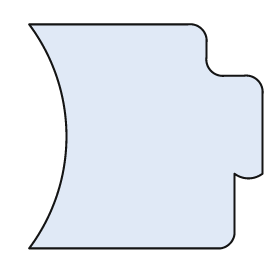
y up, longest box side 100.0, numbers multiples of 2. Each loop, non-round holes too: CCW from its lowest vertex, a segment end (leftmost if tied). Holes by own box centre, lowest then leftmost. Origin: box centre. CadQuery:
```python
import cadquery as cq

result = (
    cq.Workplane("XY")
    .moveTo(-50.0, -48.0)
    .lineTo(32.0, -48.0)
    .threePointArc((36.0, -46.0), (38.0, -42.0))
    .lineTo(38.0, -16.0)
    .threePointArc((44.0, -18.0), (50.0, -16.0))
    .lineTo(50.0, 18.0)
    .threePointArc((48.0, 24.0), (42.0, 26.0))
    .lineTo(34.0, 26.0)
    .threePointArc((28.0, 28.0), (26.0, 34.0))
    .lineTo(26.0, 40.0)
    .threePointArc((24.0, 46.0), (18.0, 48.0))
    .lineTo(-50.0, 48.0)
    .threePointArc((-34.0, 0.0), (-50.0, -48.0))
    .close()
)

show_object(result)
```